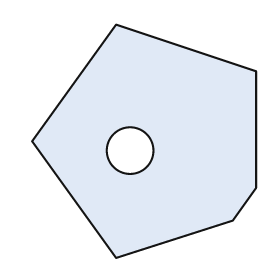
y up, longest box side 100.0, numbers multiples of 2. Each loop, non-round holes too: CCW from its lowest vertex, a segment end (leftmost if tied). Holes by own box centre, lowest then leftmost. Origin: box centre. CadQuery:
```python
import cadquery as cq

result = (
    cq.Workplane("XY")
    .moveTo(-12.0, -50.0)
    .lineTo(38.0, -34.0)
    .lineTo(48.0, -20.0)
    .lineTo(48.0, 30.0)
    .lineTo(-12.0, 50.0)
    .lineTo(-48.0, 0.0)
    .close()
    .moveTo(-6.0, -4.0)
    .circle(10.0)
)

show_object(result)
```